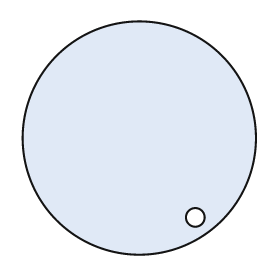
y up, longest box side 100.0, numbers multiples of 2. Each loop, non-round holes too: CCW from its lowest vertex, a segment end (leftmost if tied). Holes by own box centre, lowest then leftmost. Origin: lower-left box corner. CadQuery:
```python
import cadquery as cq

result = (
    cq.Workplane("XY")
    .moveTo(50.0, 50.0)
    .circle(50.0)
    .moveTo(74.0, 16.0)
    .circle(4.0)
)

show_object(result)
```